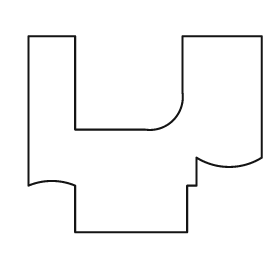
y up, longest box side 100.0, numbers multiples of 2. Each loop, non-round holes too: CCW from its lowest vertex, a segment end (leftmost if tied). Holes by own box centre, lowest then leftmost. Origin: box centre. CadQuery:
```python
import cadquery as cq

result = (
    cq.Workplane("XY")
    .moveTo(-30.0, -42.0)
    .lineTo(18.0, -42.0)
    .lineTo(18.0, -22.0)
    .lineTo(22.0, -22.0)
    .lineTo(22.0, -10.0)
    .threePointArc((36.0, -14.0), (50.0, -10.0))
    .lineTo(50.0, 42.0)
    .lineTo(16.0, 42.0)
    .lineTo(16.0, 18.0)
    .threePointArc((12.0, 6.0), (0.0, 2.0))
    .lineTo(-30.0, 2.0)
    .lineTo(-30.0, 42.0)
    .lineTo(-50.0, 42.0)
    .lineTo(-50.0, -22.0)
    .threePointArc((-40.0, -20.0), (-30.0, -22.0))
    .close()
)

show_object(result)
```